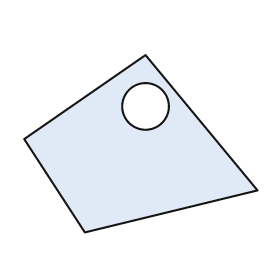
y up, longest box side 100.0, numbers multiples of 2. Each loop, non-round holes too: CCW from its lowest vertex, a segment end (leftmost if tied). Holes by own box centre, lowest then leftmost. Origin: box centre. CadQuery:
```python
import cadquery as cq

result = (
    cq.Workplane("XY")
    .moveTo(-24.0, -38.0)
    .lineTo(50.0, -20.0)
    .lineTo(2.0, 38.0)
    .lineTo(-50.0, 2.0)
    .close()
    .moveTo(2.0, 16.0)
    .circle(10.0)
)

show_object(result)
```